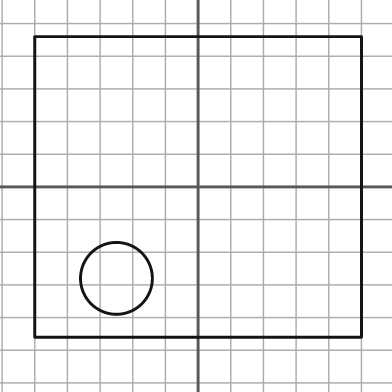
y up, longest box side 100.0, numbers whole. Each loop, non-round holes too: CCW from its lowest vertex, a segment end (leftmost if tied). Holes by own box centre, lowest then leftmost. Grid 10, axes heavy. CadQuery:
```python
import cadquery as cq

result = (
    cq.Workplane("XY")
    .moveTo(-50.0, -46.0)
    .lineTo(50.0, -46.0)
    .lineTo(50.0, 46.0)
    .lineTo(-50.0, 46.0)
    .close()
    .moveTo(-25.0, -28.0)
    .circle(11.0)
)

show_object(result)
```